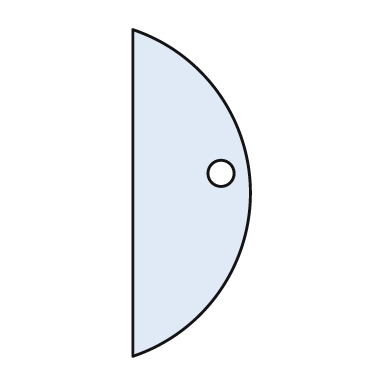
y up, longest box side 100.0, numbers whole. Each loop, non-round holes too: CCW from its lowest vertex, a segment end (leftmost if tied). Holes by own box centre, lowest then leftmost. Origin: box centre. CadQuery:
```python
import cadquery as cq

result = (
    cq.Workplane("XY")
    .moveTo(-18.0, -50.0)
    .threePointArc((18.0, 0.0), (-18.0, 50.0))
    .close()
    .moveTo(9.0, 6.0)
    .circle(4.0)
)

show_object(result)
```